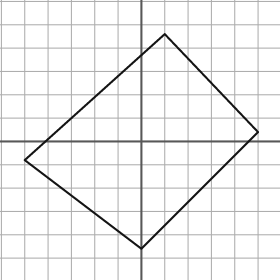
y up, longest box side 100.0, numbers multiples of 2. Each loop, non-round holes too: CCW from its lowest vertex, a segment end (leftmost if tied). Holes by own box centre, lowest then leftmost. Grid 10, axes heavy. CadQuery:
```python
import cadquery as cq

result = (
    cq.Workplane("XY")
    .moveTo(0.0, -46.0)
    .lineTo(50.0, 4.0)
    .lineTo(10.0, 46.0)
    .lineTo(-50.0, -8.0)
    .close()
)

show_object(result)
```